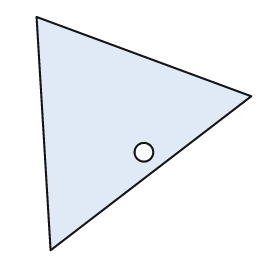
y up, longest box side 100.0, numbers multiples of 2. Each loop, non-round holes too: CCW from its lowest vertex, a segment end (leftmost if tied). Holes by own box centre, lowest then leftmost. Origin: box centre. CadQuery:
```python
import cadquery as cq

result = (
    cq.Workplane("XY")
    .moveTo(-40.0, -50.0)
    .lineTo(46.0, 16.0)
    .lineTo(-46.0, 50.0)
    .close()
    .moveTo(0.0, -8.0)
    .circle(4.0)
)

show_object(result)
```